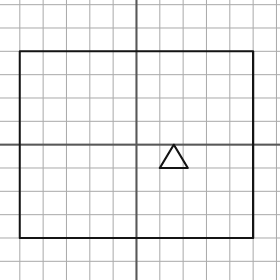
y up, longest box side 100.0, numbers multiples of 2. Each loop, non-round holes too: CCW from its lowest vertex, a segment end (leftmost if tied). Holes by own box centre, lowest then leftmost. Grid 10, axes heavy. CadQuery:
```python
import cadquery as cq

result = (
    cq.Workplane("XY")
    .moveTo(-50.0, -40.0)
    .lineTo(50.0, -40.0)
    .lineTo(50.0, 40.0)
    .lineTo(-50.0, 40.0)
    .close()
    .moveTo(10.0, -10.0)
    .lineTo(22.0, -10.0)
    .lineTo(16.0, 0.0)
    .close()
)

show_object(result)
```